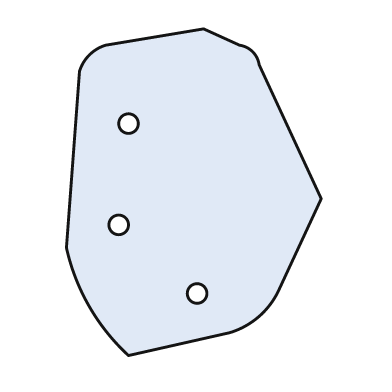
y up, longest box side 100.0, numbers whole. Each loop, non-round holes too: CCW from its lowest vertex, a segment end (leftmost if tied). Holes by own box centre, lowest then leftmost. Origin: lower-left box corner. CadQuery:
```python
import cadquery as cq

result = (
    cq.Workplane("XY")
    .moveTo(19.0, 0.0)
    .lineTo(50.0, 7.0)
    .threePointArc((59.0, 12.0), (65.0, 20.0))
    .lineTo(78.0, 48.0)
    .lineTo(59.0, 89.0)
    .threePointArc((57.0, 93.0), (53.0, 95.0))
    .lineTo(42.0, 100.0)
    .lineTo(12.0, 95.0)
    .threePointArc((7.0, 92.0), (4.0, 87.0))
    .lineTo(0.0, 33.0)
    .threePointArc((7.0, 15.0), (19.0, 0.0))
    .close()
    .moveTo(40.0, 19.0)
    .circle(3.0)
    .moveTo(16.0, 40.0)
    .circle(3.0)
    .moveTo(19.0, 71.0)
    .circle(3.0)
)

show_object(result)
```